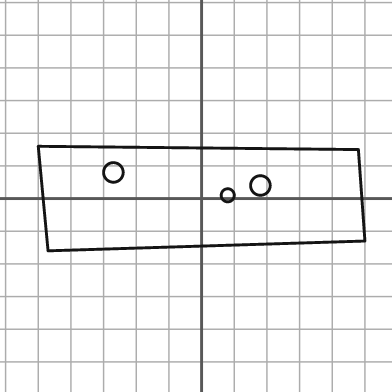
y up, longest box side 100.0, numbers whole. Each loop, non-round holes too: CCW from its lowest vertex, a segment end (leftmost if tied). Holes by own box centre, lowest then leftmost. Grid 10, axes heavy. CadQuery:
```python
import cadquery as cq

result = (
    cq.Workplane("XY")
    .moveTo(-47.0, -16.0)
    .lineTo(50.0, -13.0)
    .lineTo(48.0, 15.0)
    .lineTo(-50.0, 16.0)
    .close()
    .moveTo(8.0, 1.0)
    .circle(2.0)
    .moveTo(18.0, 4.0)
    .circle(3.0)
    .moveTo(-27.0, 8.0)
    .circle(3.0)
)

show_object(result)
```